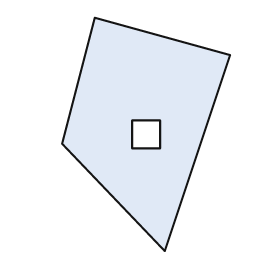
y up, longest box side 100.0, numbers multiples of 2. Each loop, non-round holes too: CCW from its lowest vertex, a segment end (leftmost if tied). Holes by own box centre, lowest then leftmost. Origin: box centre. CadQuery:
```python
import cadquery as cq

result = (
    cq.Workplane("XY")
    .moveTo(8.0, -50.0)
    .lineTo(36.0, 34.0)
    .lineTo(-22.0, 50.0)
    .lineTo(-36.0, -4.0)
    .close()
    .moveTo(-6.0, -6.0)
    .lineTo(6.0, -6.0)
    .lineTo(6.0, 6.0)
    .lineTo(-6.0, 6.0)
    .close()
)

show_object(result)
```